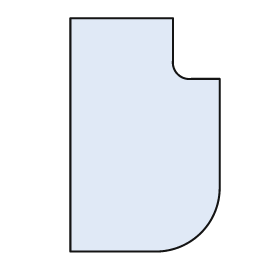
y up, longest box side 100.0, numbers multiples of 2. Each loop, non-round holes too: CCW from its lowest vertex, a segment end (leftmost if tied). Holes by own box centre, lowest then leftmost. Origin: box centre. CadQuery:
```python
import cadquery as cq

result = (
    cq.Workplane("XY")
    .moveTo(-32.0, -50.0)
    .lineTo(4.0, -50.0)
    .threePointArc((24.0, -42.0), (32.0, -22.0))
    .lineTo(32.0, 24.0)
    .lineTo(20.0, 24.0)
    .threePointArc((14.0, 26.0), (12.0, 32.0))
    .lineTo(12.0, 50.0)
    .lineTo(-32.0, 50.0)
    .close()
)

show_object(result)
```